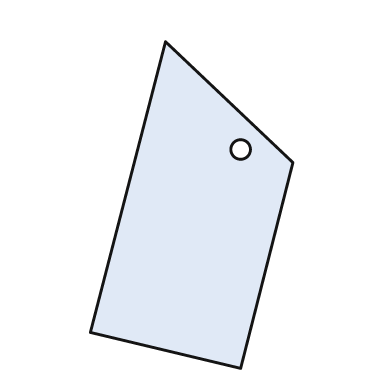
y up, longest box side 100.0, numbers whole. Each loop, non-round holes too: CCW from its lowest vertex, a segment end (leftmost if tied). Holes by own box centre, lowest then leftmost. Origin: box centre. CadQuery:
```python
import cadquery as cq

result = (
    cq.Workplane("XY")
    .moveTo(15.0, -50.0)
    .lineTo(31.0, 13.0)
    .lineTo(-8.0, 50.0)
    .lineTo(-31.0, -39.0)
    .close()
    .moveTo(15.0, 17.0)
    .circle(3.0)
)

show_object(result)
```